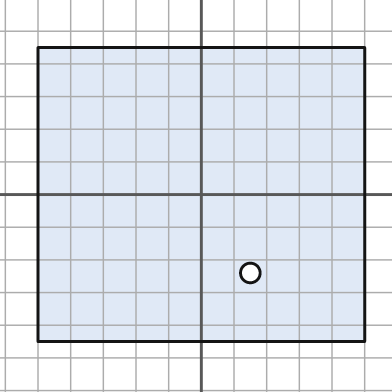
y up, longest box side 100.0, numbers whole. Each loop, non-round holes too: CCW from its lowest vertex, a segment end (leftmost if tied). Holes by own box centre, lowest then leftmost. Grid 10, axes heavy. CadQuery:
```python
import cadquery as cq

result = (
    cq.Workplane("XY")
    .moveTo(-50.0, -45.0)
    .lineTo(50.0, -45.0)
    .lineTo(50.0, 45.0)
    .lineTo(-50.0, 45.0)
    .close()
    .moveTo(15.0, -24.0)
    .circle(3.0)
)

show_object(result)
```